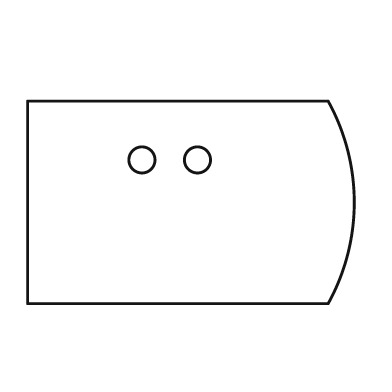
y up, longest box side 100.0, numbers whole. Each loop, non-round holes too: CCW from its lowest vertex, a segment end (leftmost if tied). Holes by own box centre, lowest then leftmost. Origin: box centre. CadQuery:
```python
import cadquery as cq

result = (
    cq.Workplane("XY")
    .moveTo(-50.0, -31.0)
    .lineTo(42.0, -31.0)
    .threePointArc((50.0, 0.0), (42.0, 31.0))
    .lineTo(-50.0, 31.0)
    .close()
    .moveTo(-15.0, 13.0)
    .circle(4.0)
    .moveTo(2.0, 13.0)
    .circle(4.0)
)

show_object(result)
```